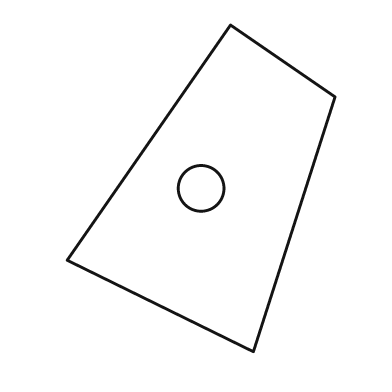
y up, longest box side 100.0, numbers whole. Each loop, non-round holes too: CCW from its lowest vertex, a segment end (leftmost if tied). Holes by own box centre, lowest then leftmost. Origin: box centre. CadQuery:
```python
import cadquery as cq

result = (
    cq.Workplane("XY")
    .moveTo(16.0, -50.0)
    .lineTo(41.0, 28.0)
    .lineTo(9.0, 50.0)
    .lineTo(-41.0, -22.0)
    .close()
    .moveTo(0.0, 0.0)
    .circle(7.0)
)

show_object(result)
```